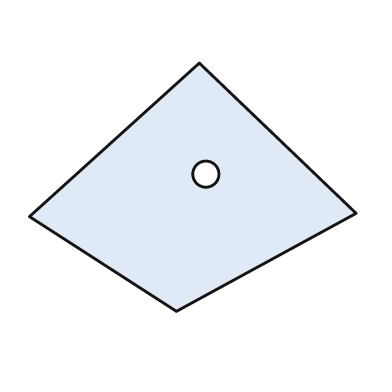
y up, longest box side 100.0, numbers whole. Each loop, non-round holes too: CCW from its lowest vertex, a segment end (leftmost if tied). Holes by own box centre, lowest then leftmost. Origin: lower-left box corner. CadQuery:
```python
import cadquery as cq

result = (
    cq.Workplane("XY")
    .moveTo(45.0, 0.0)
    .lineTo(100.0, 30.0)
    .lineTo(52.0, 76.0)
    .lineTo(0.0, 29.0)
    .close()
    .moveTo(54.0, 42.0)
    .circle(4.0)
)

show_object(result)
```